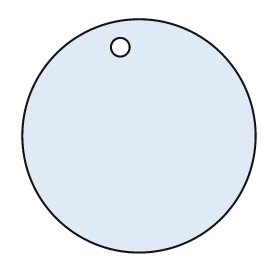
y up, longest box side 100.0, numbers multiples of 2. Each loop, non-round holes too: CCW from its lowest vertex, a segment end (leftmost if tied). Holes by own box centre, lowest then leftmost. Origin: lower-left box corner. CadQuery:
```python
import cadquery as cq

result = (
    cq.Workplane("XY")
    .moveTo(50.0, 50.0)
    .circle(50.0)
    .moveTo(42.0, 88.0)
    .circle(4.0)
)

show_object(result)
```